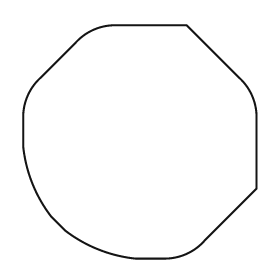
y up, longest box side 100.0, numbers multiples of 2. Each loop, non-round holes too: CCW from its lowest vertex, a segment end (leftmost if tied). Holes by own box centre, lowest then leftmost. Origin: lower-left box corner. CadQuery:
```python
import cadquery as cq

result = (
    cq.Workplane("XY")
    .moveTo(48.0, 0.0)
    .lineTo(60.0, 0.0)
    .threePointArc((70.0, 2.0), (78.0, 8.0))
    .lineTo(100.0, 30.0)
    .lineTo(100.0, 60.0)
    .threePointArc((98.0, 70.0), (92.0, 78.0))
    .lineTo(70.0, 100.0)
    .lineTo(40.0, 100.0)
    .threePointArc((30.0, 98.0), (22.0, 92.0))
    .lineTo(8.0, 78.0)
    .threePointArc((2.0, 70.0), (0.0, 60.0))
    .lineTo(0.0, 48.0)
    .threePointArc((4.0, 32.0), (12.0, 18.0))
    .lineTo(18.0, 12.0)
    .threePointArc((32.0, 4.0), (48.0, 0.0))
    .close()
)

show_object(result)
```